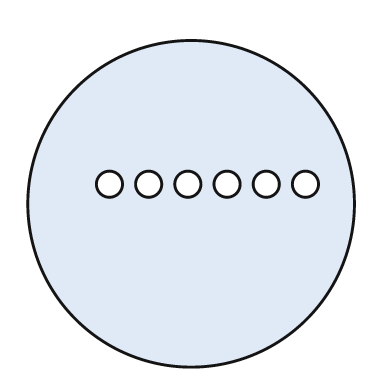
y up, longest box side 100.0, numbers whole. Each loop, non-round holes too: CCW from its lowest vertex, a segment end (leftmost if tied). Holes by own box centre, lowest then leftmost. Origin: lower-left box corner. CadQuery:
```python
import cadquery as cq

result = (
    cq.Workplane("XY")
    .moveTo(50.0, 50.0)
    .circle(50.0)
    .moveTo(25.0, 56.0)
    .circle(4.0)
    .moveTo(37.0, 56.0)
    .circle(4.0)
    .moveTo(49.0, 56.0)
    .circle(4.0)
    .moveTo(61.0, 56.0)
    .circle(4.0)
    .moveTo(73.0, 56.0)
    .circle(4.0)
    .moveTo(85.0, 56.0)
    .circle(4.0)
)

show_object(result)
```